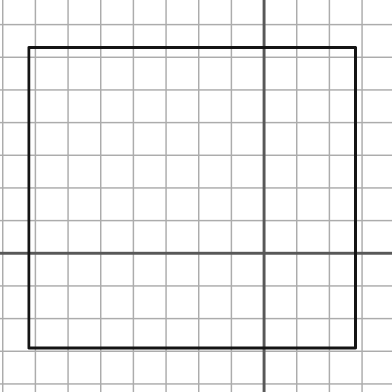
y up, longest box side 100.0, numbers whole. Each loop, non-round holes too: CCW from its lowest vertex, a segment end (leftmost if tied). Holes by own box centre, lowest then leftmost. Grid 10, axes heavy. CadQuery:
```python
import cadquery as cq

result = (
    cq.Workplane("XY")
    .moveTo(-72.0, -29.0)
    .lineTo(28.0, -29.0)
    .lineTo(28.0, 63.0)
    .lineTo(-72.0, 63.0)
    .close()
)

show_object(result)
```